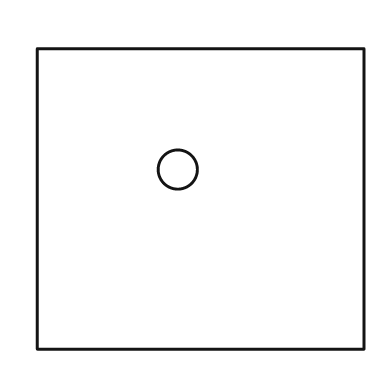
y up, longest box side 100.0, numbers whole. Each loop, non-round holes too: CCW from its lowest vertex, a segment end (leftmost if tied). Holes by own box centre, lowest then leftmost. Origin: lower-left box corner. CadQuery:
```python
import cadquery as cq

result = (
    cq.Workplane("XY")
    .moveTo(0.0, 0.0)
    .lineTo(100.0, 0.0)
    .lineTo(100.0, 92.0)
    .lineTo(0.0, 92.0)
    .close()
    .moveTo(43.0, 55.0)
    .circle(6.0)
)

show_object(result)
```